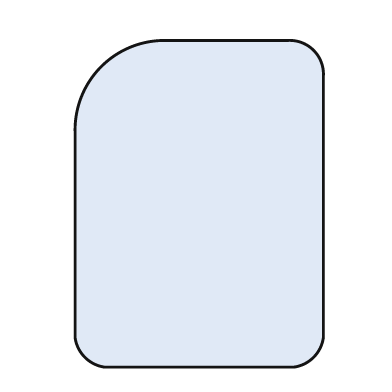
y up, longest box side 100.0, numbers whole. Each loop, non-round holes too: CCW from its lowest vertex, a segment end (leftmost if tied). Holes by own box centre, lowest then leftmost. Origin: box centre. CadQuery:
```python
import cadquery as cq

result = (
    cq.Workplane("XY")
    .moveTo(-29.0, -50.0)
    .lineTo(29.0, -50.0)
    .threePointArc((35.0, -47.0), (38.0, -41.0))
    .lineTo(38.0, 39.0)
    .threePointArc((35.0, 47.0), (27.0, 50.0))
    .lineTo(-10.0, 50.0)
    .threePointArc((-30.0, 42.0), (-38.0, 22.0))
    .lineTo(-38.0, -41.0)
    .threePointArc((-35.0, -47.0), (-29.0, -50.0))
    .close()
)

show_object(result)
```